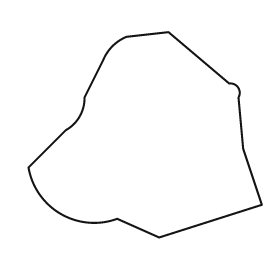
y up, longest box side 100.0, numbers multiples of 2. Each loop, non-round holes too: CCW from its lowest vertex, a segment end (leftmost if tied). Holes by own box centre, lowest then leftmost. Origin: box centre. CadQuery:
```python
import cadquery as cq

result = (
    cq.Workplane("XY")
    .moveTo(6.0, -44.0)
    .lineTo(50.0, -30.0)
    .lineTo(42.0, -6.0)
    .lineTo(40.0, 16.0)
    .threePointArc((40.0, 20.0), (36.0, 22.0))
    .lineTo(10.0, 44.0)
    .lineTo(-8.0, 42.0)
    .threePointArc((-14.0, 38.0), (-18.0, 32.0))
    .lineTo(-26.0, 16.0)
    .threePointArc((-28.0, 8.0), (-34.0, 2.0))
    .lineTo(-50.0, -14.0)
    .threePointArc((-36.0, -34.0), (-12.0, -36.0))
    .close()
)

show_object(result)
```